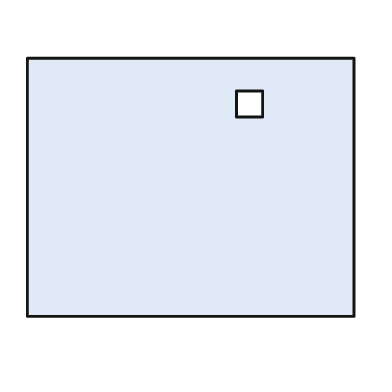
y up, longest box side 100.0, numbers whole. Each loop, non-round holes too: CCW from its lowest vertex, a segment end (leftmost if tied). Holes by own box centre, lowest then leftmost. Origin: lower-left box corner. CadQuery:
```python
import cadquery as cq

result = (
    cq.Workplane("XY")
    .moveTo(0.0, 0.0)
    .lineTo(100.0, 0.0)
    .lineTo(100.0, 79.0)
    .lineTo(0.0, 79.0)
    .close()
    .moveTo(64.0, 61.0)
    .lineTo(72.0, 61.0)
    .lineTo(72.0, 69.0)
    .lineTo(64.0, 69.0)
    .close()
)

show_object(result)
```